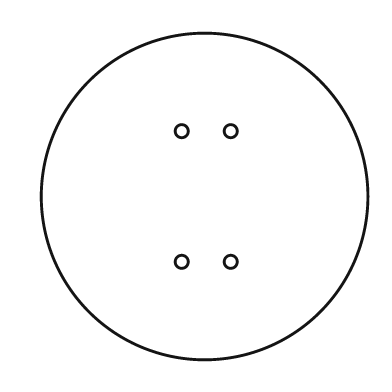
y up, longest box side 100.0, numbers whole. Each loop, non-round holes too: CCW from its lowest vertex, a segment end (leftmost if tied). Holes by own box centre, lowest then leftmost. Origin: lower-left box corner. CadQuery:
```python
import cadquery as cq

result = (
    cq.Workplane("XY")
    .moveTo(50.0, 50.0)
    .circle(50.0)
    .moveTo(43.0, 30.0)
    .circle(2.0)
    .moveTo(58.0, 30.0)
    .circle(2.0)
    .moveTo(43.0, 70.0)
    .circle(2.0)
    .moveTo(58.0, 70.0)
    .circle(2.0)
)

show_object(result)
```